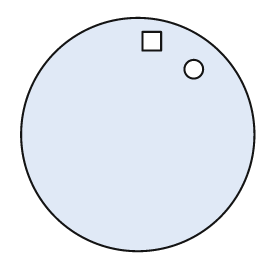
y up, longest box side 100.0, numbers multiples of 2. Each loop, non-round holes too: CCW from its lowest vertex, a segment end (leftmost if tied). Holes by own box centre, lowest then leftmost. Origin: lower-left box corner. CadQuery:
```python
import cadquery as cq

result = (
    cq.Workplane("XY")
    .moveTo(50.0, 50.0)
    .circle(50.0)
    .moveTo(74.0, 78.0)
    .circle(4.0)
    .moveTo(52.0, 86.0)
    .lineTo(60.0, 86.0)
    .lineTo(60.0, 94.0)
    .lineTo(52.0, 94.0)
    .close()
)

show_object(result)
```